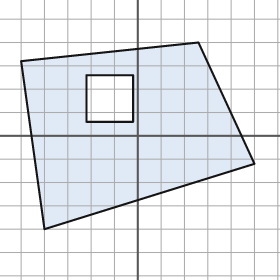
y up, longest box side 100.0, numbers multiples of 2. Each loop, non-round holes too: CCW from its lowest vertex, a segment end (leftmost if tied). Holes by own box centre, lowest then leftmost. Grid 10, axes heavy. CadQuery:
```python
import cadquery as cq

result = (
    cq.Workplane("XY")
    .moveTo(-40.0, -40.0)
    .lineTo(50.0, -12.0)
    .lineTo(26.0, 40.0)
    .lineTo(-50.0, 32.0)
    .close()
    .moveTo(-22.0, 6.0)
    .lineTo(-2.0, 6.0)
    .lineTo(-2.0, 26.0)
    .lineTo(-22.0, 26.0)
    .close()
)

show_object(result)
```